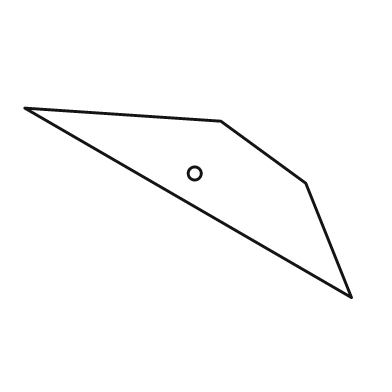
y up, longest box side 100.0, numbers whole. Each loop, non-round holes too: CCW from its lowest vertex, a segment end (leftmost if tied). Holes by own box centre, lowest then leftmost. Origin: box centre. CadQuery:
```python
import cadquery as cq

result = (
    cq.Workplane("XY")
    .moveTo(50.0, -29.0)
    .lineTo(36.0, 6.0)
    .lineTo(10.0, 25.0)
    .lineTo(-50.0, 29.0)
    .close()
    .moveTo(2.0, 9.0)
    .circle(2.0)
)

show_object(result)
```